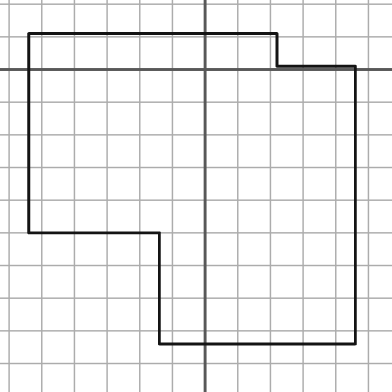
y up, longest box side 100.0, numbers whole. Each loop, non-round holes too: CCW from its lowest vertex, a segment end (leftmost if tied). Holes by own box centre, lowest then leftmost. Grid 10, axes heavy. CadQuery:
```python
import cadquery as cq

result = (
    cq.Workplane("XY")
    .moveTo(-14.0, -84.0)
    .lineTo(46.0, -84.0)
    .lineTo(46.0, 1.0)
    .lineTo(22.0, 1.0)
    .lineTo(22.0, 11.0)
    .lineTo(-54.0, 11.0)
    .lineTo(-54.0, -50.0)
    .lineTo(-14.0, -50.0)
    .close()
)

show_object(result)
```